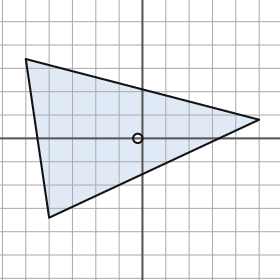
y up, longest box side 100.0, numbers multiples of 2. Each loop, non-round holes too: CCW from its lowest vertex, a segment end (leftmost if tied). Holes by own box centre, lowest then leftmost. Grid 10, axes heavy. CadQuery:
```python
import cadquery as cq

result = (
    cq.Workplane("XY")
    .moveTo(-40.0, -34.0)
    .lineTo(50.0, 8.0)
    .lineTo(-50.0, 34.0)
    .close()
    .moveTo(-2.0, 0.0)
    .circle(2.0)
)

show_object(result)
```